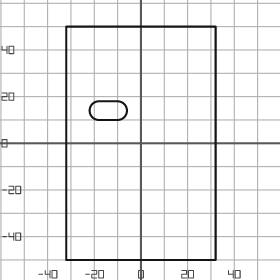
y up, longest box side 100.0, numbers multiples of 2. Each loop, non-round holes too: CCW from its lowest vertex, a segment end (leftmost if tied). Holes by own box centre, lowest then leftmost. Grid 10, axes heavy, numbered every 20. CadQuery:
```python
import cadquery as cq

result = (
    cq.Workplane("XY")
    .moveTo(-32.0, -50.0)
    .lineTo(32.0, -50.0)
    .lineTo(32.0, 50.0)
    .lineTo(-32.0, 50.0)
    .close()
    .moveTo(-18.0, 10.0)
    .lineTo(-10.0, 10.0)
    .threePointArc((-6.0, 14.0), (-10.0, 18.0))
    .lineTo(-18.0, 18.0)
    .threePointArc((-22.0, 14.0), (-18.0, 10.0))
    .close()
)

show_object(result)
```